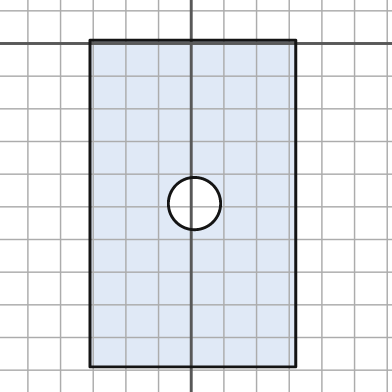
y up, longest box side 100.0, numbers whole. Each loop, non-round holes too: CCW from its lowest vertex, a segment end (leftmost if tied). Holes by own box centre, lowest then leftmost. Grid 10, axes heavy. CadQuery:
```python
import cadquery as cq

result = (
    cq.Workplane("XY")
    .moveTo(-31.0, -99.0)
    .lineTo(32.0, -99.0)
    .lineTo(32.0, 1.0)
    .lineTo(-31.0, 1.0)
    .close()
    .moveTo(1.0, -49.0)
    .circle(8.0)
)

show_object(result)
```